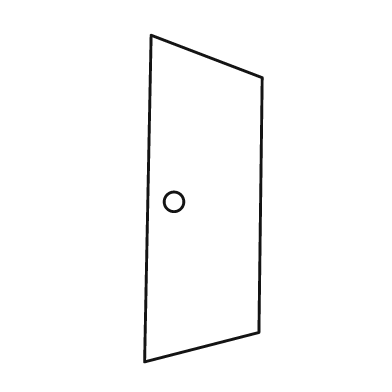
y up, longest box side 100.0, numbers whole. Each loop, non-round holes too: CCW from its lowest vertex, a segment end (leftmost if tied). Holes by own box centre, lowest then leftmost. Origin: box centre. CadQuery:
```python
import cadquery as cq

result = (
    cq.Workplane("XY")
    .moveTo(-18.0, -50.0)
    .lineTo(17.0, -41.0)
    .lineTo(18.0, 37.0)
    .lineTo(-16.0, 50.0)
    .close()
    .moveTo(-9.0, -1.0)
    .circle(3.0)
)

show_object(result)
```